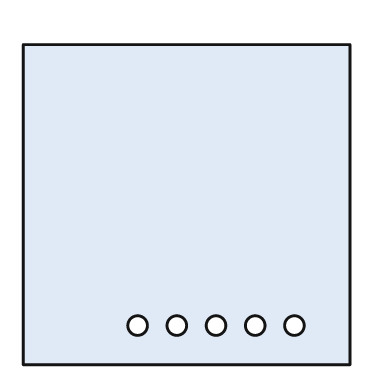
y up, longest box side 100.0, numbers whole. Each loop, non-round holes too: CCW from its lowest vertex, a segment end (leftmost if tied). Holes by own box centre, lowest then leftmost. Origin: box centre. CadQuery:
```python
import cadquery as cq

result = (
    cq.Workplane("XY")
    .moveTo(-50.0, -49.0)
    .lineTo(50.0, -49.0)
    .lineTo(50.0, 49.0)
    .lineTo(-50.0, 49.0)
    .close()
    .moveTo(-15.0, -37.0)
    .circle(3.0)
    .moveTo(-3.0, -37.0)
    .circle(3.0)
    .moveTo(9.0, -37.0)
    .circle(3.0)
    .moveTo(21.0, -37.0)
    .circle(3.0)
    .moveTo(33.0, -37.0)
    .circle(3.0)
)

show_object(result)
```